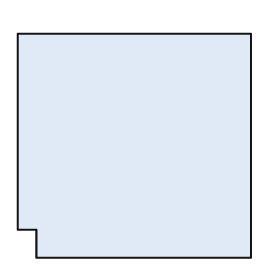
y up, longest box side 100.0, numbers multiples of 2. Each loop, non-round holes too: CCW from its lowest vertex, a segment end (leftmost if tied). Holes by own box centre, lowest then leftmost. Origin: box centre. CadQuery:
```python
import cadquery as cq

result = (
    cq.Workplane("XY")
    .moveTo(-42.0, -48.0)
    .lineTo(50.0, -48.0)
    .lineTo(50.0, 48.0)
    .lineTo(-50.0, 48.0)
    .lineTo(-50.0, -36.0)
    .lineTo(-42.0, -36.0)
    .close()
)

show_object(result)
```